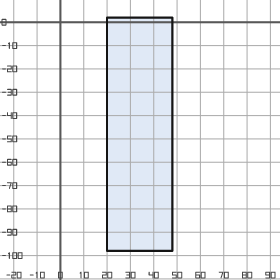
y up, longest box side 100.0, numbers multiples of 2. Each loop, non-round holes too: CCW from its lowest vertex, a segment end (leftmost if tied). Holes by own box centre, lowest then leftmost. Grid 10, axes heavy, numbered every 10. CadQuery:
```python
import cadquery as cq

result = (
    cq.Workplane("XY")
    .moveTo(20.0, -98.0)
    .lineTo(48.0, -98.0)
    .lineTo(48.0, 2.0)
    .lineTo(20.0, 2.0)
    .close()
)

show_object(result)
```